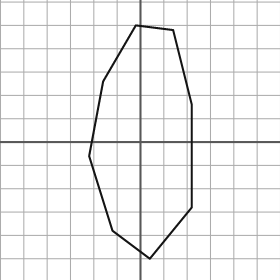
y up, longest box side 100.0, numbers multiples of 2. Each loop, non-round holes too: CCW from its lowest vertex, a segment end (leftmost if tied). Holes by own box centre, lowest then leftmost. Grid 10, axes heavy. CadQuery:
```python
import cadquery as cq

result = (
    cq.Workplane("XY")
    .moveTo(4.0, -50.0)
    .lineTo(22.0, -28.0)
    .lineTo(22.0, 16.0)
    .lineTo(14.0, 48.0)
    .lineTo(-2.0, 50.0)
    .lineTo(-16.0, 26.0)
    .lineTo(-22.0, -6.0)
    .lineTo(-12.0, -38.0)
    .close()
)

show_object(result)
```